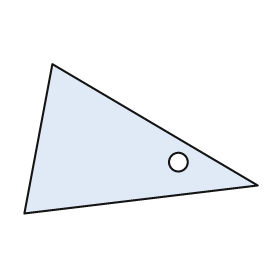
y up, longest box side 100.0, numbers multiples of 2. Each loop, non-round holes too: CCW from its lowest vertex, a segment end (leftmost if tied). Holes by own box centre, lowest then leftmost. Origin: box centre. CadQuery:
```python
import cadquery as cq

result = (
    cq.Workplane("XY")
    .moveTo(-50.0, -32.0)
    .lineTo(50.0, -20.0)
    .lineTo(-38.0, 32.0)
    .close()
    .moveTo(16.0, -10.0)
    .circle(4.0)
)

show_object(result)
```